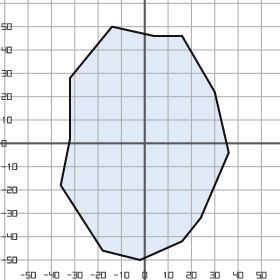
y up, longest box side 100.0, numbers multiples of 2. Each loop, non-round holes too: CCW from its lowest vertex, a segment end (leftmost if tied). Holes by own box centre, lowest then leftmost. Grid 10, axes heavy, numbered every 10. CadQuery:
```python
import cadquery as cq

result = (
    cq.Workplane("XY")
    .moveTo(-2.0, -50.0)
    .lineTo(16.0, -42.0)
    .lineTo(24.0, -32.0)
    .lineTo(36.0, -4.0)
    .lineTo(30.0, 22.0)
    .lineTo(16.0, 46.0)
    .lineTo(4.0, 46.0)
    .lineTo(-14.0, 50.0)
    .lineTo(-32.0, 28.0)
    .lineTo(-32.0, 2.0)
    .lineTo(-36.0, -18.0)
    .lineTo(-18.0, -46.0)
    .close()
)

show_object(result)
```